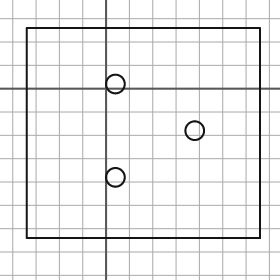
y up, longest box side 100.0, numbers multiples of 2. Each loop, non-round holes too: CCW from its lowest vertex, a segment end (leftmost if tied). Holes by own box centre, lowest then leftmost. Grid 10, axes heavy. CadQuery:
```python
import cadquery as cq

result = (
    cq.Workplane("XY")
    .moveTo(-34.0, -64.0)
    .lineTo(66.0, -64.0)
    .lineTo(66.0, 26.0)
    .lineTo(-34.0, 26.0)
    .close()
    .moveTo(4.0, -38.0)
    .circle(4.0)
    .moveTo(38.0, -18.0)
    .circle(4.0)
    .moveTo(4.0, 2.0)
    .circle(4.0)
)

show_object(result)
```